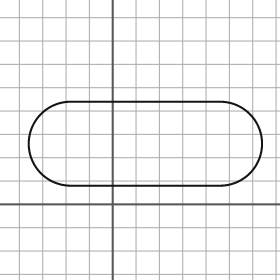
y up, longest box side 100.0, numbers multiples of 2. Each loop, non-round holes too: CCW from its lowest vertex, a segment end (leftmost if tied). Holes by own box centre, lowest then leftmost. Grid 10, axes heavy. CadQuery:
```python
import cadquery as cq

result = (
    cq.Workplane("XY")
    .moveTo(-18.0, 8.0)
    .lineTo(46.0, 8.0)
    .threePointArc((64.0, 26.0), (46.0, 44.0))
    .lineTo(-18.0, 44.0)
    .threePointArc((-36.0, 26.0), (-18.0, 8.0))
    .close()
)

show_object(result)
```